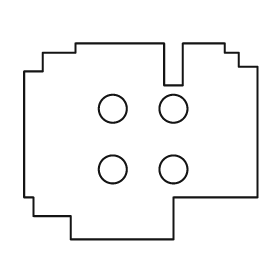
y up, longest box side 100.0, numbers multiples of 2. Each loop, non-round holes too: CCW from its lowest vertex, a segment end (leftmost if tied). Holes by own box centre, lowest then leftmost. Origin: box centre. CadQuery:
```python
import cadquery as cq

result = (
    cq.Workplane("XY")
    .moveTo(-30.0, -42.0)
    .lineTo(14.0, -42.0)
    .lineTo(14.0, -24.0)
    .lineTo(50.0, -24.0)
    .lineTo(50.0, 32.0)
    .lineTo(42.0, 32.0)
    .lineTo(42.0, 38.0)
    .lineTo(36.0, 38.0)
    .lineTo(36.0, 42.0)
    .lineTo(18.0, 42.0)
    .lineTo(18.0, 24.0)
    .lineTo(10.0, 24.0)
    .lineTo(10.0, 42.0)
    .lineTo(-28.0, 42.0)
    .lineTo(-28.0, 38.0)
    .lineTo(-42.0, 38.0)
    .lineTo(-42.0, 30.0)
    .lineTo(-50.0, 30.0)
    .lineTo(-50.0, -24.0)
    .lineTo(-46.0, -24.0)
    .lineTo(-46.0, -32.0)
    .lineTo(-30.0, -32.0)
    .close()
    .moveTo(-12.0, -12.0)
    .circle(6.0)
    .moveTo(14.0, -12.0)
    .circle(6.0)
    .moveTo(-12.0, 14.0)
    .circle(6.0)
    .moveTo(14.0, 14.0)
    .circle(6.0)
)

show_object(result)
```